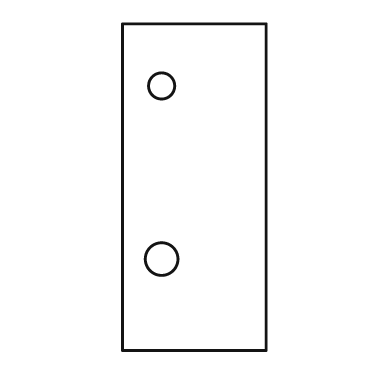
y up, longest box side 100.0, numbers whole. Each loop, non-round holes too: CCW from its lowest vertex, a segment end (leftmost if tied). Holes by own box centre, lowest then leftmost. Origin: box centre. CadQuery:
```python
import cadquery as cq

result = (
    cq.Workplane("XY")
    .moveTo(-22.0, -50.0)
    .lineTo(22.0, -50.0)
    .lineTo(22.0, 50.0)
    .lineTo(-22.0, 50.0)
    .close()
    .moveTo(-10.0, -22.0)
    .circle(5.0)
    .moveTo(-10.0, 31.0)
    .circle(4.0)
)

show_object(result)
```